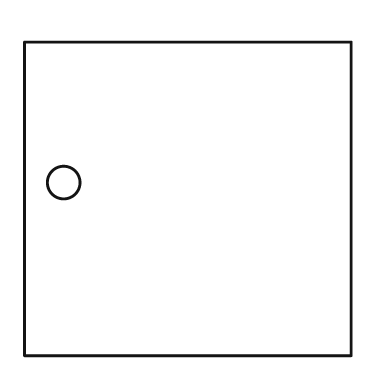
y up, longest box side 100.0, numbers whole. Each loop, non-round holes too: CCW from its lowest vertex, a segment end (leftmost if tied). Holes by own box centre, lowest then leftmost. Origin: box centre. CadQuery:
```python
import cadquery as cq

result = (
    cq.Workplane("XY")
    .moveTo(-50.0, -48.0)
    .lineTo(50.0, -48.0)
    .lineTo(50.0, 48.0)
    .lineTo(-50.0, 48.0)
    .close()
    .moveTo(-38.0, 5.0)
    .circle(5.0)
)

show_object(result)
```